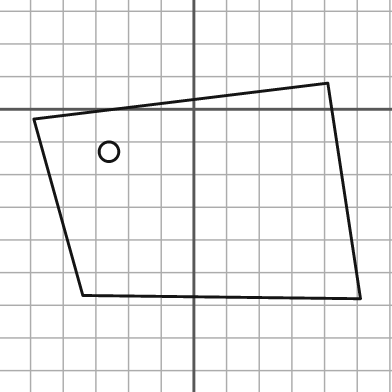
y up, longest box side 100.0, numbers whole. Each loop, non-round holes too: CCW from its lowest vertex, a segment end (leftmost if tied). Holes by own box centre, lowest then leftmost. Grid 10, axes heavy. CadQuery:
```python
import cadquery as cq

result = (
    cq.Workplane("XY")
    .moveTo(51.0, -58.0)
    .lineTo(41.0, 8.0)
    .lineTo(-49.0, -3.0)
    .lineTo(-34.0, -57.0)
    .close()
    .moveTo(-26.0, -13.0)
    .circle(3.0)
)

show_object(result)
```